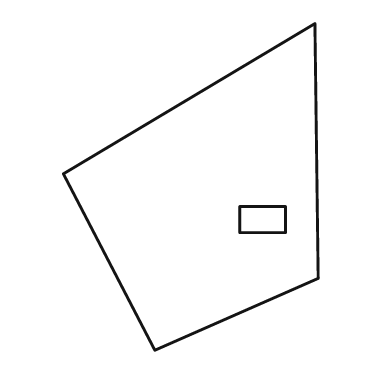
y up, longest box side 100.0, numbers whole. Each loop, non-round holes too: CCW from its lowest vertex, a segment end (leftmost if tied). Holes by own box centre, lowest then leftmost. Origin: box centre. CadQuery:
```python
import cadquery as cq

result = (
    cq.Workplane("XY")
    .moveTo(-11.0, -50.0)
    .lineTo(39.0, -28.0)
    .lineTo(38.0, 50.0)
    .lineTo(-39.0, 4.0)
    .close()
    .moveTo(15.0, -14.0)
    .lineTo(29.0, -14.0)
    .lineTo(29.0, -6.0)
    .lineTo(15.0, -6.0)
    .close()
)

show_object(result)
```